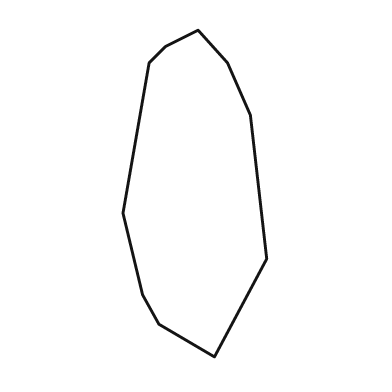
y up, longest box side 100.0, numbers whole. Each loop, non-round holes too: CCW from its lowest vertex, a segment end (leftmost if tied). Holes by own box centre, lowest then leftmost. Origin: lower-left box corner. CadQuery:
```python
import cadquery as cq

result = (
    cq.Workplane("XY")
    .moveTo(28.0, 0.0)
    .lineTo(44.0, 30.0)
    .lineTo(39.0, 74.0)
    .lineTo(32.0, 90.0)
    .lineTo(23.0, 100.0)
    .lineTo(13.0, 95.0)
    .lineTo(8.0, 90.0)
    .lineTo(0.0, 44.0)
    .lineTo(6.0, 19.0)
    .lineTo(11.0, 10.0)
    .close()
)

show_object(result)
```